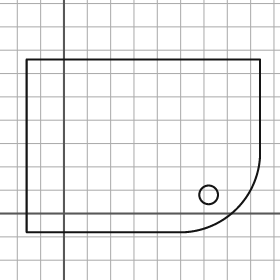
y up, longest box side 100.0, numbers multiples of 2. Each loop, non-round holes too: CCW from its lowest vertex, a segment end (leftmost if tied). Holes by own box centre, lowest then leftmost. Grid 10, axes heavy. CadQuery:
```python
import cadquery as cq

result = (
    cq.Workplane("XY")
    .moveTo(-16.0, -8.0)
    .lineTo(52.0, -8.0)
    .threePointArc((74.0, 2.0), (84.0, 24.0))
    .lineTo(84.0, 66.0)
    .lineTo(-16.0, 66.0)
    .close()
    .moveTo(62.0, 8.0)
    .circle(4.0)
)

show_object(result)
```